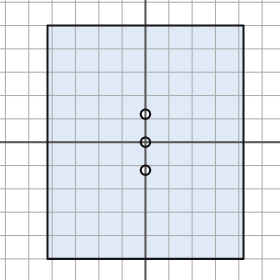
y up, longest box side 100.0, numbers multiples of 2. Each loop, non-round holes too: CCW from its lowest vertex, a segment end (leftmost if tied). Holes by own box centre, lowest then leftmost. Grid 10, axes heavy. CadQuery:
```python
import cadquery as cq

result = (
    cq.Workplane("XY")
    .moveTo(-42.0, -50.0)
    .lineTo(42.0, -50.0)
    .lineTo(42.0, 50.0)
    .lineTo(-42.0, 50.0)
    .close()
    .moveTo(0.0, -12.0)
    .circle(2.0)
    .moveTo(0.0, 0.0)
    .circle(2.0)
    .moveTo(0.0, 12.0)
    .circle(2.0)
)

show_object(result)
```